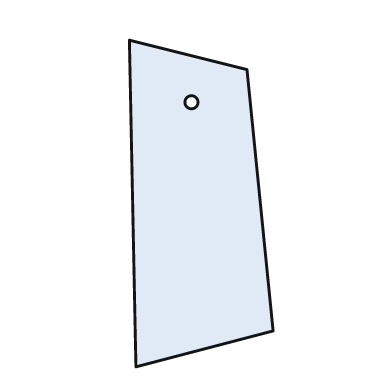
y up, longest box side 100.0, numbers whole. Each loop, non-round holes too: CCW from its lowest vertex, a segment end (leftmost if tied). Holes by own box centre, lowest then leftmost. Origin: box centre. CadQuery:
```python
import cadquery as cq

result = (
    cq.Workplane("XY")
    .moveTo(-20.0, -50.0)
    .lineTo(22.0, -39.0)
    .lineTo(14.0, 41.0)
    .lineTo(-22.0, 50.0)
    .close()
    .moveTo(-3.0, 31.0)
    .circle(2.0)
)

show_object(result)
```